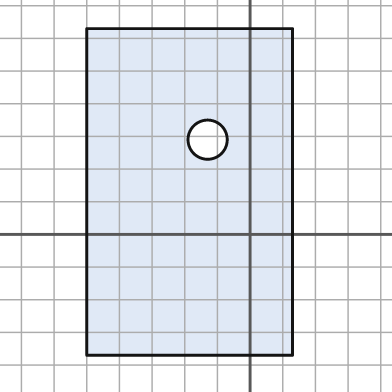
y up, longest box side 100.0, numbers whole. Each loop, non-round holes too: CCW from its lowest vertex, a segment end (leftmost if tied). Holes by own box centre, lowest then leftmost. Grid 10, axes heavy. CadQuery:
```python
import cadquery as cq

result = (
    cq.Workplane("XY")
    .moveTo(-50.0, -37.0)
    .lineTo(13.0, -37.0)
    .lineTo(13.0, 63.0)
    .lineTo(-50.0, 63.0)
    .close()
    .moveTo(-13.0, 29.0)
    .circle(6.0)
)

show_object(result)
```